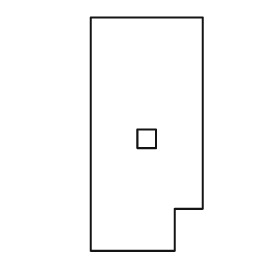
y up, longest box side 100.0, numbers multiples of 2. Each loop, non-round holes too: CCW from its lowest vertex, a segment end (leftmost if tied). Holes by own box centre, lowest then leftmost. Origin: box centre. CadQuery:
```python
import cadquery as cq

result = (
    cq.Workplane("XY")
    .moveTo(-24.0, -50.0)
    .lineTo(12.0, -50.0)
    .lineTo(12.0, -32.0)
    .lineTo(24.0, -32.0)
    .lineTo(24.0, 50.0)
    .lineTo(-24.0, 50.0)
    .close()
    .moveTo(-4.0, -6.0)
    .lineTo(4.0, -6.0)
    .lineTo(4.0, 2.0)
    .lineTo(-4.0, 2.0)
    .close()
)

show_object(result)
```